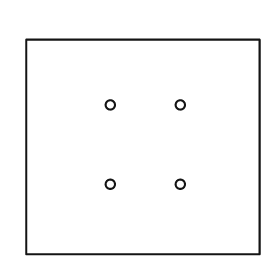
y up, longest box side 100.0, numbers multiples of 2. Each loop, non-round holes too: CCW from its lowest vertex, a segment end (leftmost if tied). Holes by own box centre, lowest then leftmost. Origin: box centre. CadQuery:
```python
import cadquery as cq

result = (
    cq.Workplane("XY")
    .moveTo(-50.0, -46.0)
    .lineTo(50.0, -46.0)
    .lineTo(50.0, 46.0)
    .lineTo(-50.0, 46.0)
    .close()
    .moveTo(-14.0, -16.0)
    .circle(2.0)
    .moveTo(16.0, -16.0)
    .circle(2.0)
    .moveTo(-14.0, 18.0)
    .circle(2.0)
    .moveTo(16.0, 18.0)
    .circle(2.0)
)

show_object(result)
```